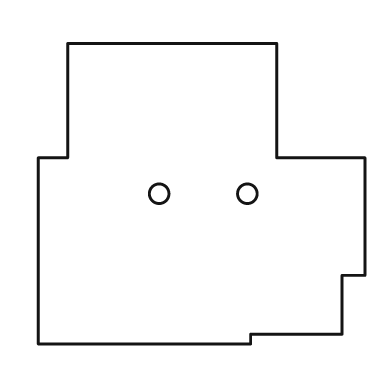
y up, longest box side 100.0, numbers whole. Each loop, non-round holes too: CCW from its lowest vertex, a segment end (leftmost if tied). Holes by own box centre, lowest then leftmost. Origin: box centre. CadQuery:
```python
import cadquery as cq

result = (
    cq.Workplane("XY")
    .moveTo(-50.0, -46.0)
    .lineTo(15.0, -46.0)
    .lineTo(15.0, -43.0)
    .lineTo(43.0, -43.0)
    .lineTo(43.0, -25.0)
    .lineTo(50.0, -25.0)
    .lineTo(50.0, 11.0)
    .lineTo(23.0, 11.0)
    .lineTo(23.0, 46.0)
    .lineTo(-41.0, 46.0)
    .lineTo(-41.0, 11.0)
    .lineTo(-50.0, 11.0)
    .close()
    .moveTo(-13.0, 0.0)
    .circle(3.0)
    .moveTo(14.0, 0.0)
    .circle(3.0)
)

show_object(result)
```